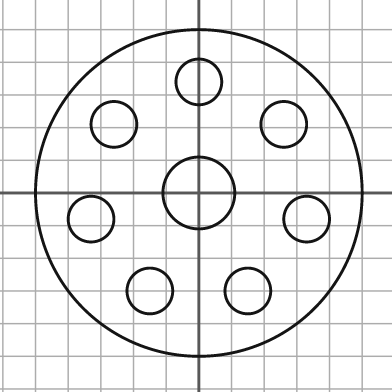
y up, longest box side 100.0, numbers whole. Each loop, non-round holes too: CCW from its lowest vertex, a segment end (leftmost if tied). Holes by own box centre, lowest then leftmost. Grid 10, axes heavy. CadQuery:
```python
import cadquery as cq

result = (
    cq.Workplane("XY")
    .moveTo(0.0, 0.0)
    .circle(50.0)
    .moveTo(-15.0, -30.0)
    .circle(7.0)
    .moveTo(15.0, -30.0)
    .circle(7.0)
    .moveTo(-33.0, -8.0)
    .circle(7.0)
    .moveTo(33.0, -8.0)
    .circle(7.0)
    .moveTo(0.0, 0.0)
    .circle(11.0)
    .moveTo(-26.0, 21.0)
    .circle(7.0)
    .moveTo(26.0, 21.0)
    .circle(7.0)
    .moveTo(0.0, 34.0)
    .circle(7.0)
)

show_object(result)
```